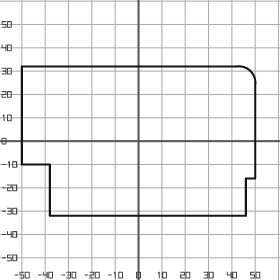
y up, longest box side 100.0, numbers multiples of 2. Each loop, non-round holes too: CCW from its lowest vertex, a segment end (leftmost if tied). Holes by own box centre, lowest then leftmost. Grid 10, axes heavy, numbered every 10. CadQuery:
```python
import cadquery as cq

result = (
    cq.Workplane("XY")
    .moveTo(-38.0, -32.0)
    .lineTo(46.0, -32.0)
    .lineTo(46.0, -16.0)
    .lineTo(50.0, -16.0)
    .lineTo(50.0, 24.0)
    .threePointArc((48.0, 30.0), (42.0, 32.0))
    .lineTo(-50.0, 32.0)
    .lineTo(-50.0, -10.0)
    .lineTo(-38.0, -10.0)
    .close()
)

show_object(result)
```